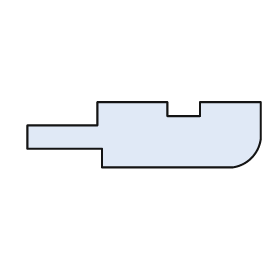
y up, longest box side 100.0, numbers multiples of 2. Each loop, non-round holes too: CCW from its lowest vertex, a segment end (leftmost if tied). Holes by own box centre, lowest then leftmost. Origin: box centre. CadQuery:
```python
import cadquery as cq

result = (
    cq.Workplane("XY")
    .moveTo(-18.0, -14.0)
    .lineTo(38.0, -14.0)
    .threePointArc((46.0, -10.0), (50.0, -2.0))
    .lineTo(50.0, 14.0)
    .lineTo(24.0, 14.0)
    .lineTo(24.0, 8.0)
    .lineTo(10.0, 8.0)
    .lineTo(10.0, 14.0)
    .lineTo(-20.0, 14.0)
    .lineTo(-20.0, 4.0)
    .lineTo(-50.0, 4.0)
    .lineTo(-50.0, -6.0)
    .lineTo(-18.0, -6.0)
    .close()
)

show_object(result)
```